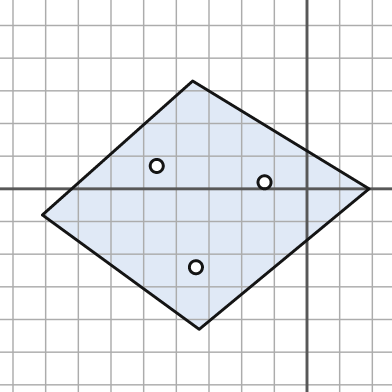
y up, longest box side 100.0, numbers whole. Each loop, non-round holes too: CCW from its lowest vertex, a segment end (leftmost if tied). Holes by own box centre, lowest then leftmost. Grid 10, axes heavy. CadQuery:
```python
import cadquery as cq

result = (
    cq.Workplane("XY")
    .moveTo(-33.0, -43.0)
    .lineTo(19.0, 0.0)
    .lineTo(-35.0, 33.0)
    .lineTo(-81.0, -8.0)
    .close()
    .moveTo(-34.0, -24.0)
    .circle(2.0)
    .moveTo(-13.0, 2.0)
    .circle(2.0)
    .moveTo(-46.0, 7.0)
    .circle(2.0)
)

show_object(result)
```